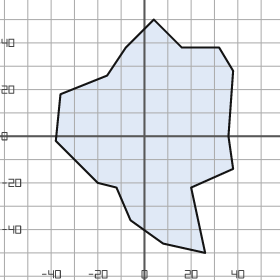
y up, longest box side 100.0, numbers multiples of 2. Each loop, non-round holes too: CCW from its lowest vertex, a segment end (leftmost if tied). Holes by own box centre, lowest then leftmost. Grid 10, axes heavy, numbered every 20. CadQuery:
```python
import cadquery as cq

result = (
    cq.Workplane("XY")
    .moveTo(26.0, -50.0)
    .lineTo(20.0, -22.0)
    .lineTo(38.0, -14.0)
    .lineTo(36.0, 0.0)
    .lineTo(38.0, 28.0)
    .lineTo(32.0, 38.0)
    .lineTo(16.0, 38.0)
    .lineTo(4.0, 50.0)
    .lineTo(-8.0, 38.0)
    .lineTo(-16.0, 26.0)
    .lineTo(-36.0, 18.0)
    .lineTo(-38.0, -2.0)
    .lineTo(-20.0, -20.0)
    .lineTo(-12.0, -22.0)
    .lineTo(-6.0, -36.0)
    .lineTo(8.0, -46.0)
    .close()
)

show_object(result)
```